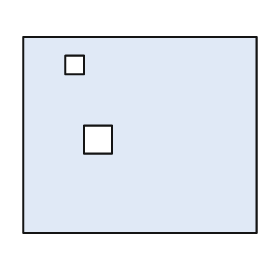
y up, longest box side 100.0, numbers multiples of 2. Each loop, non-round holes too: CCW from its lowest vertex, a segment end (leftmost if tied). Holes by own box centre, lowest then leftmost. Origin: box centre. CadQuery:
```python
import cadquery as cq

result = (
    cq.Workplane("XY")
    .moveTo(-50.0, -42.0)
    .lineTo(50.0, -42.0)
    .lineTo(50.0, 42.0)
    .lineTo(-50.0, 42.0)
    .close()
    .moveTo(-24.0, -8.0)
    .lineTo(-12.0, -8.0)
    .lineTo(-12.0, 4.0)
    .lineTo(-24.0, 4.0)
    .close()
    .moveTo(-32.0, 26.0)
    .lineTo(-24.0, 26.0)
    .lineTo(-24.0, 34.0)
    .lineTo(-32.0, 34.0)
    .close()
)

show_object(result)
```